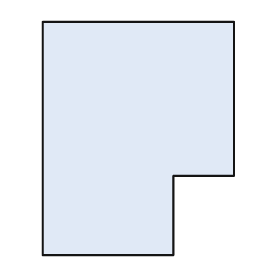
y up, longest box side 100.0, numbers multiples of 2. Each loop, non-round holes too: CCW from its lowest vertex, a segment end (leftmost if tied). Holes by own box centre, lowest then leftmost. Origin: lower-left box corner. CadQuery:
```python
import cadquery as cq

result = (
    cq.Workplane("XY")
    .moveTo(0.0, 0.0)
    .lineTo(56.0, 0.0)
    .lineTo(56.0, 34.0)
    .lineTo(82.0, 34.0)
    .lineTo(82.0, 100.0)
    .lineTo(0.0, 100.0)
    .close()
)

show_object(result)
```